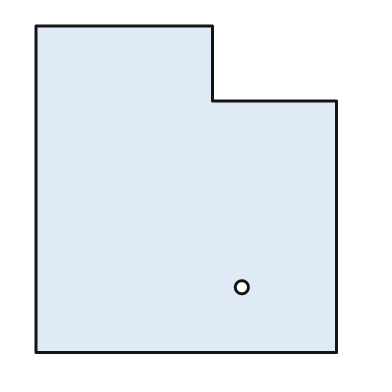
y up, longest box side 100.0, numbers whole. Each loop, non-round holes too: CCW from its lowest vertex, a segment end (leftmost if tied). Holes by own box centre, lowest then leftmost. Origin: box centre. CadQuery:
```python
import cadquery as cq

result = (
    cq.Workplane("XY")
    .moveTo(-46.0, -50.0)
    .lineTo(46.0, -50.0)
    .lineTo(46.0, 27.0)
    .lineTo(8.0, 27.0)
    .lineTo(8.0, 50.0)
    .lineTo(-46.0, 50.0)
    .close()
    .moveTo(17.0, -30.0)
    .circle(2.0)
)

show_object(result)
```